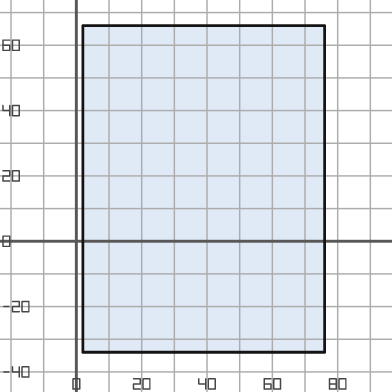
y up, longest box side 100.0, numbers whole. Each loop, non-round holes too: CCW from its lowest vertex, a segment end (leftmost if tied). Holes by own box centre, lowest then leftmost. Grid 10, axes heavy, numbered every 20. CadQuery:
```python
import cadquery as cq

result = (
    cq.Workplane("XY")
    .moveTo(2.0, -34.0)
    .lineTo(76.0, -34.0)
    .lineTo(76.0, 66.0)
    .lineTo(2.0, 66.0)
    .close()
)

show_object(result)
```